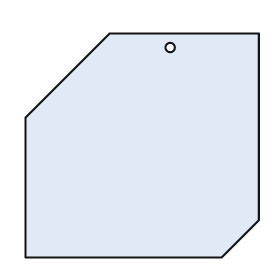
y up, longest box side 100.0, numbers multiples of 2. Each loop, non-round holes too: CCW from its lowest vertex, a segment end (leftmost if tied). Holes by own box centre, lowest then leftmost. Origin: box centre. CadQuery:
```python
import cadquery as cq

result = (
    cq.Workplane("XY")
    .moveTo(-50.0, -48.0)
    .lineTo(34.0, -48.0)
    .lineTo(50.0, -32.0)
    .lineTo(50.0, 48.0)
    .lineTo(-14.0, 48.0)
    .lineTo(-50.0, 12.0)
    .close()
    .moveTo(12.0, 42.0)
    .circle(2.0)
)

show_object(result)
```